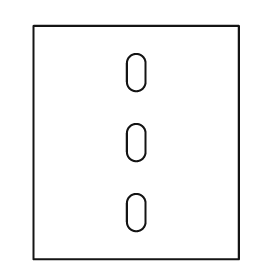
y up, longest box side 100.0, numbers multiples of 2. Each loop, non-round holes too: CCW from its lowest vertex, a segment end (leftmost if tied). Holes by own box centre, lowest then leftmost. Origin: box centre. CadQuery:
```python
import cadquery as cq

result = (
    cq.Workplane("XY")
    .moveTo(-44.0, -50.0)
    .lineTo(44.0, -50.0)
    .lineTo(44.0, 50.0)
    .lineTo(-44.0, 50.0)
    .close()
    .moveTo(-4.0, -34.0)
    .threePointArc((0.0, -38.0), (4.0, -34.0))
    .lineTo(4.0, -26.0)
    .threePointArc((0.0, -22.0), (-4.0, -26.0))
    .close()
    .moveTo(-4.0, -4.0)
    .threePointArc((0.0, -8.0), (4.0, -4.0))
    .lineTo(4.0, 4.0)
    .threePointArc((0.0, 8.0), (-4.0, 4.0))
    .close()
    .moveTo(-4.0, 26.0)
    .threePointArc((0.0, 22.0), (4.0, 26.0))
    .lineTo(4.0, 34.0)
    .threePointArc((0.0, 38.0), (-4.0, 34.0))
    .close()
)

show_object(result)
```